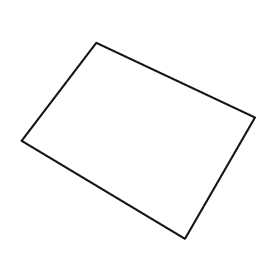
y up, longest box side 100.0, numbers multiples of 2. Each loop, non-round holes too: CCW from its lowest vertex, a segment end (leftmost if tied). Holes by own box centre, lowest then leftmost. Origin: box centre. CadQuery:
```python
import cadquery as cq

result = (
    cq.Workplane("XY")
    .moveTo(20.0, -42.0)
    .lineTo(50.0, 10.0)
    .lineTo(-18.0, 42.0)
    .lineTo(-50.0, 0.0)
    .close()
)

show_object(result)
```